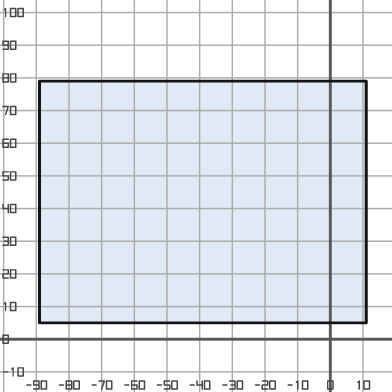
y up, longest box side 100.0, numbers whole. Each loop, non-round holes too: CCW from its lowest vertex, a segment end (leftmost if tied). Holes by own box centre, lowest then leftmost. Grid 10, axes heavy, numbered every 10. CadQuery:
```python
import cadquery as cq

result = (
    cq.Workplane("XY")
    .moveTo(-89.0, 5.0)
    .lineTo(11.0, 5.0)
    .lineTo(11.0, 79.0)
    .lineTo(-89.0, 79.0)
    .close()
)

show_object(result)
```